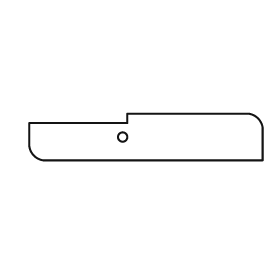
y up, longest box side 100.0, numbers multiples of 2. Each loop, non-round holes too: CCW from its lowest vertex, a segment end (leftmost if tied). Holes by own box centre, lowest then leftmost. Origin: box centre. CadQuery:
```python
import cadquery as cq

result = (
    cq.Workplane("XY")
    .moveTo(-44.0, -10.0)
    .lineTo(50.0, -10.0)
    .lineTo(50.0, 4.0)
    .threePointArc((48.0, 8.0), (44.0, 10.0))
    .lineTo(-8.0, 10.0)
    .lineTo(-8.0, 6.0)
    .lineTo(-50.0, 6.0)
    .lineTo(-50.0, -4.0)
    .threePointArc((-48.0, -8.0), (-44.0, -10.0))
    .close()
    .moveTo(-10.0, 0.0)
    .circle(2.0)
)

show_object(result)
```